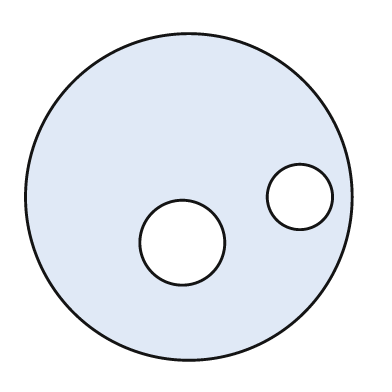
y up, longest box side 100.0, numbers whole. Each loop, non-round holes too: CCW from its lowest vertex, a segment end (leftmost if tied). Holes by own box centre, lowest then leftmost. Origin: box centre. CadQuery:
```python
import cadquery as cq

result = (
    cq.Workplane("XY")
    .moveTo(0.0, 0.0)
    .circle(50.0)
    .moveTo(-2.0, -14.0)
    .circle(13.0)
    .moveTo(34.0, 0.0)
    .circle(10.0)
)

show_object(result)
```